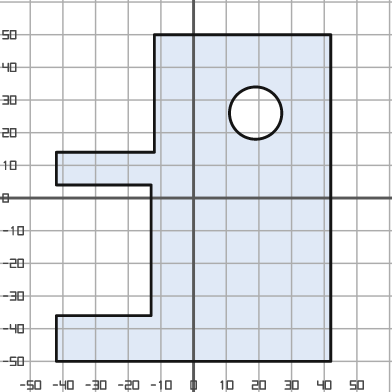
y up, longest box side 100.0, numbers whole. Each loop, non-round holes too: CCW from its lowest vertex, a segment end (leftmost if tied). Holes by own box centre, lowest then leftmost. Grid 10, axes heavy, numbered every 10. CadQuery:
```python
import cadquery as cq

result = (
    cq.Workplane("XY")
    .moveTo(-42.0, -50.0)
    .lineTo(42.0, -50.0)
    .lineTo(42.0, 50.0)
    .lineTo(-12.0, 50.0)
    .lineTo(-12.0, 14.0)
    .lineTo(-42.0, 14.0)
    .lineTo(-42.0, 4.0)
    .lineTo(-13.0, 4.0)
    .lineTo(-13.0, -36.0)
    .lineTo(-42.0, -36.0)
    .close()
    .moveTo(19.0, 26.0)
    .circle(8.0)
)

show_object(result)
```